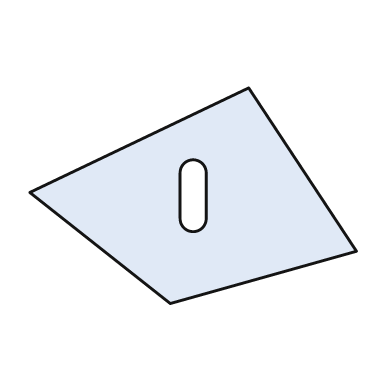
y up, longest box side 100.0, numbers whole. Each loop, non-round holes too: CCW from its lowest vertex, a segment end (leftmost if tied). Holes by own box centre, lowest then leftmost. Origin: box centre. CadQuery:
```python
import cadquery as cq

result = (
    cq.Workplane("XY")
    .moveTo(-7.0, -33.0)
    .lineTo(50.0, -17.0)
    .lineTo(17.0, 33.0)
    .lineTo(-50.0, 1.0)
    .close()
    .moveTo(-4.0, -7.0)
    .threePointArc((0.0, -11.0), (4.0, -7.0))
    .lineTo(4.0, 7.0)
    .threePointArc((0.0, 11.0), (-4.0, 7.0))
    .close()
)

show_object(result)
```